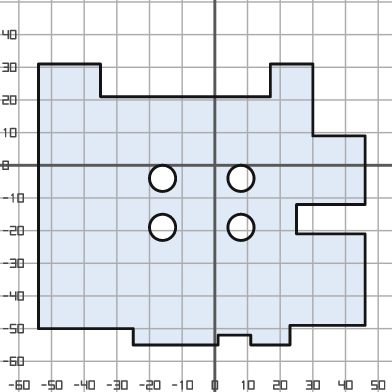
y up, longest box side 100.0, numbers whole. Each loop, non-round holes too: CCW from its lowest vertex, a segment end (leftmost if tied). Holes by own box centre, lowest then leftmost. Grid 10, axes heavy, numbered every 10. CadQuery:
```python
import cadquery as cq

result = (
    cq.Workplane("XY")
    .moveTo(-25.0, -55.0)
    .lineTo(1.0, -55.0)
    .lineTo(1.0, -52.0)
    .lineTo(11.0, -52.0)
    .lineTo(11.0, -55.0)
    .lineTo(23.0, -55.0)
    .lineTo(23.0, -49.0)
    .lineTo(46.0, -49.0)
    .lineTo(46.0, -21.0)
    .lineTo(25.0, -21.0)
    .lineTo(25.0, -12.0)
    .lineTo(46.0, -12.0)
    .lineTo(46.0, 9.0)
    .lineTo(30.0, 9.0)
    .lineTo(30.0, 31.0)
    .lineTo(17.0, 31.0)
    .lineTo(17.0, 21.0)
    .lineTo(-35.0, 21.0)
    .lineTo(-35.0, 31.0)
    .lineTo(-54.0, 31.0)
    .lineTo(-54.0, -50.0)
    .lineTo(-25.0, -50.0)
    .close()
    .moveTo(-16.0, -19.0)
    .circle(4.0)
    .moveTo(8.0, -19.0)
    .circle(4.0)
    .moveTo(-16.0, -4.0)
    .circle(4.0)
    .moveTo(8.0, -4.0)
    .circle(4.0)
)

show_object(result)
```